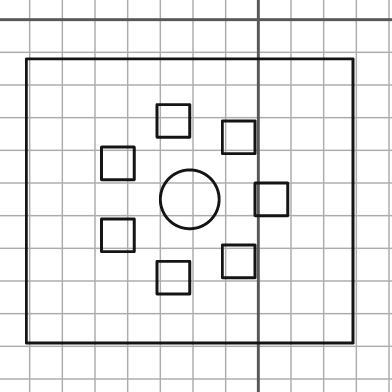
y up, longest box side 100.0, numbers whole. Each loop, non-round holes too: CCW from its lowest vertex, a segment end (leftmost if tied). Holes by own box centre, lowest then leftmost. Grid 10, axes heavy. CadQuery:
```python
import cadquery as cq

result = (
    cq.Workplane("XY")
    .moveTo(-71.0, -99.0)
    .lineTo(29.0, -99.0)
    .lineTo(29.0, -12.0)
    .lineTo(-71.0, -12.0)
    .close()
    .moveTo(-31.0, -84.0)
    .lineTo(-21.0, -84.0)
    .lineTo(-21.0, -74.0)
    .lineTo(-31.0, -74.0)
    .close()
    .moveTo(-11.0, -79.0)
    .lineTo(-1.0, -79.0)
    .lineTo(-1.0, -69.0)
    .lineTo(-11.0, -69.0)
    .close()
    .moveTo(-48.0, -71.0)
    .lineTo(-38.0, -71.0)
    .lineTo(-38.0, -61.0)
    .lineTo(-48.0, -61.0)
    .close()
    .moveTo(-21.0, -55.0)
    .circle(9.0)
    .moveTo(-1.0, -60.0)
    .lineTo(9.0, -60.0)
    .lineTo(9.0, -50.0)
    .lineTo(-1.0, -50.0)
    .close()
    .moveTo(-48.0, -49.0)
    .lineTo(-38.0, -49.0)
    .lineTo(-38.0, -39.0)
    .lineTo(-48.0, -39.0)
    .close()
    .moveTo(-11.0, -41.0)
    .lineTo(-1.0, -41.0)
    .lineTo(-1.0, -31.0)
    .lineTo(-11.0, -31.0)
    .close()
    .moveTo(-31.0, -36.0)
    .lineTo(-21.0, -36.0)
    .lineTo(-21.0, -26.0)
    .lineTo(-31.0, -26.0)
    .close()
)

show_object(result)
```